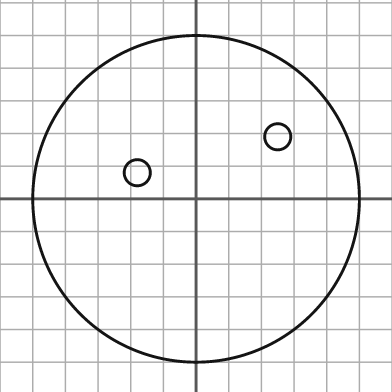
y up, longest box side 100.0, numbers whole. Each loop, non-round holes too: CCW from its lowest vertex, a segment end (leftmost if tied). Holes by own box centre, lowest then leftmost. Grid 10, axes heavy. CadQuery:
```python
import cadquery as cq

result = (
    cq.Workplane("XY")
    .moveTo(0.0, 0.0)
    .circle(50.0)
    .moveTo(-18.0, 8.0)
    .circle(4.0)
    .moveTo(25.0, 19.0)
    .circle(4.0)
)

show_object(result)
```